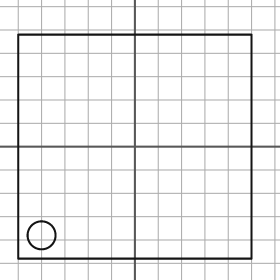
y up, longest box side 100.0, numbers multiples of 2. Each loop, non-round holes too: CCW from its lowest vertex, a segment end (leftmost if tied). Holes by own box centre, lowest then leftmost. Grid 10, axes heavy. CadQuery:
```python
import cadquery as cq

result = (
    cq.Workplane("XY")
    .moveTo(-50.0, -48.0)
    .lineTo(50.0, -48.0)
    .lineTo(50.0, 48.0)
    .lineTo(-50.0, 48.0)
    .close()
    .moveTo(-40.0, -38.0)
    .circle(6.0)
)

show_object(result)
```